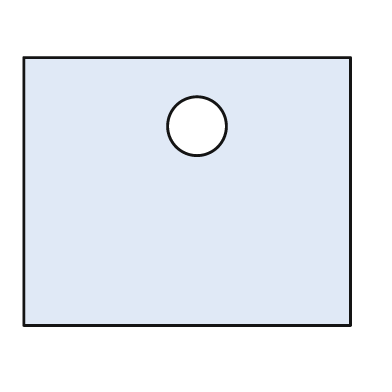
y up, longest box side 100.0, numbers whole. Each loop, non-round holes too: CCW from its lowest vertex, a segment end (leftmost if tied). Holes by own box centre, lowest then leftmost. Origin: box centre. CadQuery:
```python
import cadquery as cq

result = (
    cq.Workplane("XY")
    .moveTo(-50.0, -41.0)
    .lineTo(50.0, -41.0)
    .lineTo(50.0, 41.0)
    .lineTo(-50.0, 41.0)
    .close()
    .moveTo(3.0, 20.0)
    .circle(9.0)
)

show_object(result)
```